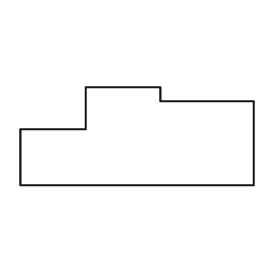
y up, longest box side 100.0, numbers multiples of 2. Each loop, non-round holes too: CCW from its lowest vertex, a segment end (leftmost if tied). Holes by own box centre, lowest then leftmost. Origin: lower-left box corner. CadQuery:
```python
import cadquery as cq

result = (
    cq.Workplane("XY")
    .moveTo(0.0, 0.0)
    .lineTo(100.0, 0.0)
    .lineTo(100.0, 36.0)
    .lineTo(60.0, 36.0)
    .lineTo(60.0, 42.0)
    .lineTo(28.0, 42.0)
    .lineTo(28.0, 24.0)
    .lineTo(0.0, 24.0)
    .close()
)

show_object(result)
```